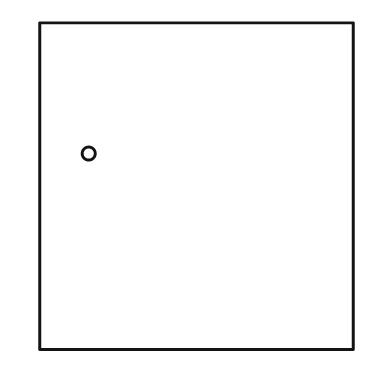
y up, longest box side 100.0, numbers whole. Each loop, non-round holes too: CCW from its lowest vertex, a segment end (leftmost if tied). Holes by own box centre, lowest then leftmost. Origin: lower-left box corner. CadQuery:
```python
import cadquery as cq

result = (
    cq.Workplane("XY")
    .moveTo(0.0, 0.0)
    .lineTo(96.0, 0.0)
    .lineTo(96.0, 100.0)
    .lineTo(0.0, 100.0)
    .close()
    .moveTo(15.0, 60.0)
    .circle(2.0)
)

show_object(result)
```